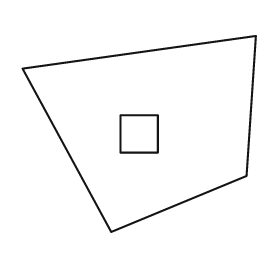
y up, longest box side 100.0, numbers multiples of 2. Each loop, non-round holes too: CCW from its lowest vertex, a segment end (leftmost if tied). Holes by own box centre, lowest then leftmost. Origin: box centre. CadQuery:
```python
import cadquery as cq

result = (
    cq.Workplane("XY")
    .moveTo(-12.0, -42.0)
    .lineTo(46.0, -18.0)
    .lineTo(50.0, 42.0)
    .lineTo(-50.0, 28.0)
    .close()
    .moveTo(-8.0, -8.0)
    .lineTo(8.0, -8.0)
    .lineTo(8.0, 8.0)
    .lineTo(-8.0, 8.0)
    .close()
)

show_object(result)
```